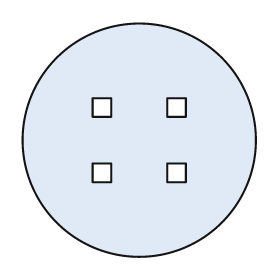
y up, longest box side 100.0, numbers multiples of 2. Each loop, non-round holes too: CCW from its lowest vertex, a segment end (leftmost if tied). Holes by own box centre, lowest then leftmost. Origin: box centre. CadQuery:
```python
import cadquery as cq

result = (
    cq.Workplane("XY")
    .moveTo(0.0, 0.0)
    .circle(50.0)
    .moveTo(-20.0, -18.0)
    .lineTo(-12.0, -18.0)
    .lineTo(-12.0, -10.0)
    .lineTo(-20.0, -10.0)
    .close()
    .moveTo(12.0, -18.0)
    .lineTo(20.0, -18.0)
    .lineTo(20.0, -10.0)
    .lineTo(12.0, -10.0)
    .close()
    .moveTo(-20.0, 10.0)
    .lineTo(-12.0, 10.0)
    .lineTo(-12.0, 18.0)
    .lineTo(-20.0, 18.0)
    .close()
    .moveTo(12.0, 10.0)
    .lineTo(20.0, 10.0)
    .lineTo(20.0, 18.0)
    .lineTo(12.0, 18.0)
    .close()
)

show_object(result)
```